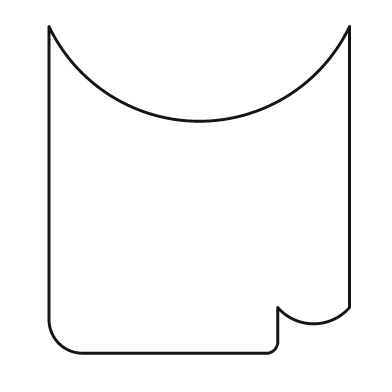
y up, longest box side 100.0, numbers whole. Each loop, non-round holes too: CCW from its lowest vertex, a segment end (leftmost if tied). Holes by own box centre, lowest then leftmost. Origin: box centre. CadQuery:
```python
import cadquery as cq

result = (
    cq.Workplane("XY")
    .moveTo(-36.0, -50.0)
    .lineTo(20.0, -50.0)
    .threePointArc((23.0, -49.0), (24.0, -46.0))
    .lineTo(24.0, -36.0)
    .threePointArc((35.0, -41.0), (46.0, -36.0))
    .lineTo(46.0, 50.0)
    .threePointArc((0.0, 21.0), (-46.0, 50.0))
    .lineTo(-46.0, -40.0)
    .threePointArc((-43.0, -47.0), (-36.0, -50.0))
    .close()
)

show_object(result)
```